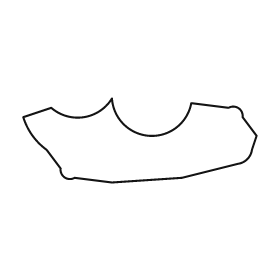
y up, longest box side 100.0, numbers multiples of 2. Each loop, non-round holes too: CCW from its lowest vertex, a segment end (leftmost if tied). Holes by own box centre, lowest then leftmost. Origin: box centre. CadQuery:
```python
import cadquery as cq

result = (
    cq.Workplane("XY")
    .moveTo(-12.0, -18.0)
    .lineTo(18.0, -16.0)
    .lineTo(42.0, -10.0)
    .threePointArc((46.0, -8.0), (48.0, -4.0))
    .lineTo(50.0, 2.0)
    .lineTo(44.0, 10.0)
    .threePointArc((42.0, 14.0), (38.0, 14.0))
    .lineTo(22.0, 16.0)
    .threePointArc((4.0, 2.0), (-12.0, 18.0))
    .threePointArc((-24.0, 10.0), (-38.0, 14.0))
    .lineTo(-50.0, 10.0)
    .threePointArc((-46.0, 2.0), (-40.0, -4.0))
    .lineTo(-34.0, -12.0)
    .threePointArc((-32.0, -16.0), (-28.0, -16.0))
    .close()
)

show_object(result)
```